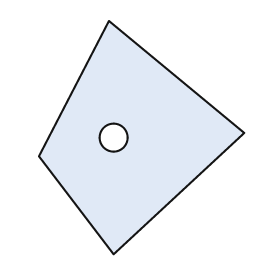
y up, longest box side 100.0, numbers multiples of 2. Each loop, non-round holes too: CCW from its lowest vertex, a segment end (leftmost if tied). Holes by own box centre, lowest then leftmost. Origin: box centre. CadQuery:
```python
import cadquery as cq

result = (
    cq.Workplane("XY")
    .moveTo(-12.0, -50.0)
    .lineTo(44.0, 2.0)
    .lineTo(-14.0, 50.0)
    .lineTo(-44.0, -8.0)
    .close()
    .moveTo(-12.0, 0.0)
    .circle(6.0)
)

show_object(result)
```